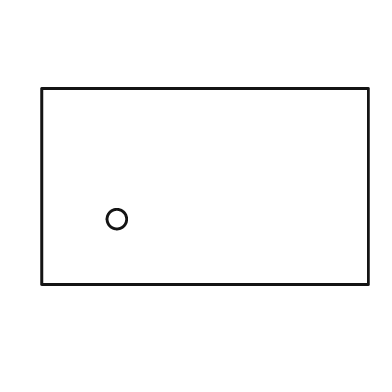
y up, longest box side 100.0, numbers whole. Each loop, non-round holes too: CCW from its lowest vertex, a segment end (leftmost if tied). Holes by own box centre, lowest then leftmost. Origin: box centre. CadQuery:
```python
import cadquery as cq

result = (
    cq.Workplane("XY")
    .moveTo(-50.0, -30.0)
    .lineTo(50.0, -30.0)
    .lineTo(50.0, 30.0)
    .lineTo(-50.0, 30.0)
    .close()
    .moveTo(-27.0, -10.0)
    .circle(3.0)
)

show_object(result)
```